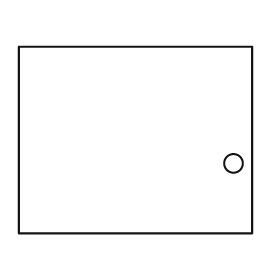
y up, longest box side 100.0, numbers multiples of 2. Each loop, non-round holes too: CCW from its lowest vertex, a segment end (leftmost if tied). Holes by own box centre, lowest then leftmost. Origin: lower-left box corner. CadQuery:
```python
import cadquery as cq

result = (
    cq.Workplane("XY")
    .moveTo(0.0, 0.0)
    .lineTo(100.0, 0.0)
    .lineTo(100.0, 80.0)
    .lineTo(0.0, 80.0)
    .close()
    .moveTo(92.0, 30.0)
    .circle(4.0)
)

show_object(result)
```